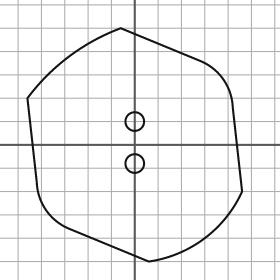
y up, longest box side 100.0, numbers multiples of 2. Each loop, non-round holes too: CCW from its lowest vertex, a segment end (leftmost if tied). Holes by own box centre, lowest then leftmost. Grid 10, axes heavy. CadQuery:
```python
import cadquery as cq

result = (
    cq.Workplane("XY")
    .moveTo(6.0, -50.0)
    .threePointArc((30.0, -40.0), (46.0, -20.0))
    .lineTo(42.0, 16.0)
    .threePointArc((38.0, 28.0), (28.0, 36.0))
    .lineTo(-6.0, 50.0)
    .threePointArc((-28.0, 38.0), (-46.0, 20.0))
    .lineTo(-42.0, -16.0)
    .threePointArc((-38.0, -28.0), (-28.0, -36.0))
    .close()
    .moveTo(0.0, -8.0)
    .circle(4.0)
    .moveTo(0.0, 10.0)
    .circle(4.0)
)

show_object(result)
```